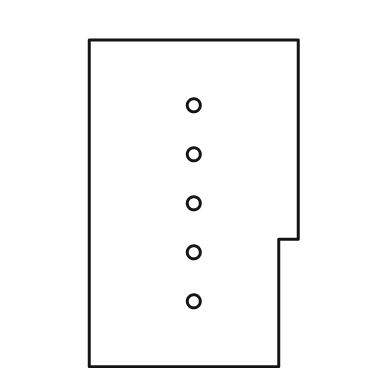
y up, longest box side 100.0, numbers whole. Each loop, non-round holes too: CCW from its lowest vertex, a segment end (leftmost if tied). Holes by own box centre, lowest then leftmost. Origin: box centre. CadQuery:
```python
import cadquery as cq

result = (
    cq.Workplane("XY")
    .moveTo(-32.0, -50.0)
    .lineTo(26.0, -50.0)
    .lineTo(26.0, -11.0)
    .lineTo(32.0, -11.0)
    .lineTo(32.0, 50.0)
    .lineTo(-32.0, 50.0)
    .close()
    .moveTo(0.0, -30.0)
    .circle(2.0)
    .moveTo(0.0, -15.0)
    .circle(2.0)
    .moveTo(0.0, 0.0)
    .circle(2.0)
    .moveTo(0.0, 15.0)
    .circle(2.0)
    .moveTo(0.0, 30.0)
    .circle(2.0)
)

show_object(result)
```